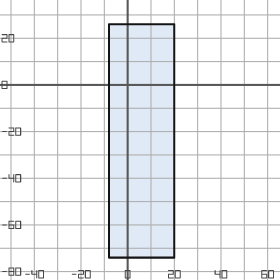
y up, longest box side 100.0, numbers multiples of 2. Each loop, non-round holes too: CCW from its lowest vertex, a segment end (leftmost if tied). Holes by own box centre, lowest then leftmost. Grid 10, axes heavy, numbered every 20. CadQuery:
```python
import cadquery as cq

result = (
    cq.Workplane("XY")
    .moveTo(-8.0, -74.0)
    .lineTo(20.0, -74.0)
    .lineTo(20.0, 26.0)
    .lineTo(-8.0, 26.0)
    .close()
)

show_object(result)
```